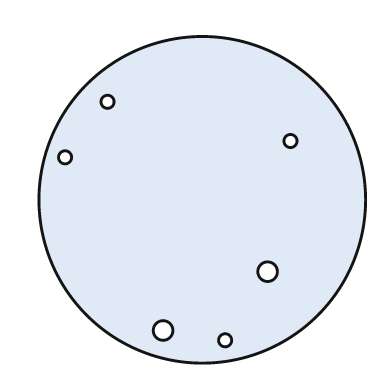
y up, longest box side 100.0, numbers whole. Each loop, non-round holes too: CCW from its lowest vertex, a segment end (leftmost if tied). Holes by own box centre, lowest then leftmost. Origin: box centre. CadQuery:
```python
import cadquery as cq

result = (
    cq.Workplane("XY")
    .moveTo(0.0, 0.0)
    .circle(50.0)
    .moveTo(7.0, -43.0)
    .circle(2.0)
    .moveTo(-12.0, -40.0)
    .circle(3.0)
    .moveTo(20.0, -22.0)
    .circle(3.0)
    .moveTo(-42.0, 13.0)
    .circle(2.0)
    .moveTo(27.0, 18.0)
    .circle(2.0)
    .moveTo(-29.0, 30.0)
    .circle(2.0)
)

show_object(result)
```